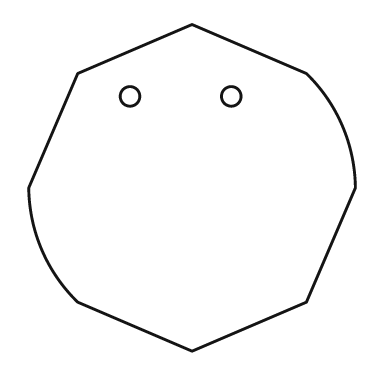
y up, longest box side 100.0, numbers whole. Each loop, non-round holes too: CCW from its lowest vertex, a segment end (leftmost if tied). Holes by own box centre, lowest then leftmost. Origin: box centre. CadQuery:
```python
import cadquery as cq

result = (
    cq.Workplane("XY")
    .moveTo(0.0, -50.0)
    .lineTo(35.0, -35.0)
    .lineTo(50.0, 0.0)
    .threePointArc((46.0, 19.0), (35.0, 35.0))
    .lineTo(0.0, 50.0)
    .lineTo(-35.0, 35.0)
    .lineTo(-50.0, 0.0)
    .threePointArc((-46.0, -19.0), (-35.0, -35.0))
    .close()
    .moveTo(-19.0, 28.0)
    .circle(3.0)
    .moveTo(12.0, 28.0)
    .circle(3.0)
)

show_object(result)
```